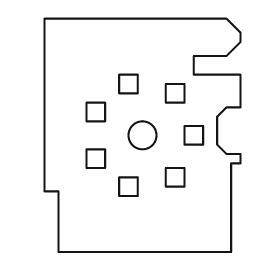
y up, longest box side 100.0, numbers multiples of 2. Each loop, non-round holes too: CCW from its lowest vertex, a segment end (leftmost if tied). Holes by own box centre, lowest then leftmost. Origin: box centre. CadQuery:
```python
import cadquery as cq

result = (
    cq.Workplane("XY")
    .moveTo(-36.0, -50.0)
    .lineTo(38.0, -50.0)
    .lineTo(38.0, -12.0)
    .lineTo(42.0, -12.0)
    .lineTo(42.0, -8.0)
    .lineTo(36.0, -8.0)
    .lineTo(32.0, -4.0)
    .lineTo(32.0, 8.0)
    .lineTo(36.0, 12.0)
    .lineTo(42.0, 12.0)
    .lineTo(42.0, 26.0)
    .lineTo(22.0, 26.0)
    .lineTo(22.0, 34.0)
    .lineTo(36.0, 34.0)
    .lineTo(42.0, 40.0)
    .lineTo(42.0, 44.0)
    .lineTo(36.0, 50.0)
    .lineTo(-42.0, 50.0)
    .lineTo(-42.0, -24.0)
    .lineTo(-36.0, -24.0)
    .close()
    .moveTo(-10.0, -26.0)
    .lineTo(-2.0, -26.0)
    .lineTo(-2.0, -18.0)
    .lineTo(-10.0, -18.0)
    .close()
    .moveTo(10.0, -22.0)
    .lineTo(18.0, -22.0)
    .lineTo(18.0, -14.0)
    .lineTo(10.0, -14.0)
    .close()
    .moveTo(-24.0, -14.0)
    .lineTo(-16.0, -14.0)
    .lineTo(-16.0, -6.0)
    .lineTo(-24.0, -6.0)
    .close()
    .moveTo(0.0, 0.0)
    .circle(6.0)
    .moveTo(18.0, -4.0)
    .lineTo(26.0, -4.0)
    .lineTo(26.0, 4.0)
    .lineTo(18.0, 4.0)
    .close()
    .moveTo(-24.0, 6.0)
    .lineTo(-16.0, 6.0)
    .lineTo(-16.0, 14.0)
    .lineTo(-24.0, 14.0)
    .close()
    .moveTo(10.0, 14.0)
    .lineTo(18.0, 14.0)
    .lineTo(18.0, 22.0)
    .lineTo(10.0, 22.0)
    .close()
    .moveTo(-10.0, 18.0)
    .lineTo(-2.0, 18.0)
    .lineTo(-2.0, 26.0)
    .lineTo(-10.0, 26.0)
    .close()
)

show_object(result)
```